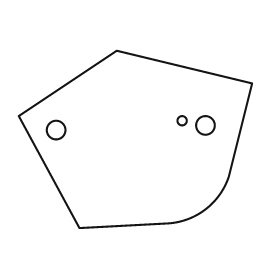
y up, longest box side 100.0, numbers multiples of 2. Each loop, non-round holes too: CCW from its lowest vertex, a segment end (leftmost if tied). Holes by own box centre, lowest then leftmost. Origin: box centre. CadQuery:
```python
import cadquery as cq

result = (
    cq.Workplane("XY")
    .moveTo(-24.0, -38.0)
    .lineTo(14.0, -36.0)
    .threePointArc((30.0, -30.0), (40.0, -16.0))
    .lineTo(50.0, 24.0)
    .lineTo(-8.0, 38.0)
    .lineTo(-50.0, 10.0)
    .close()
    .moveTo(-34.0, 4.0)
    .circle(4.0)
    .moveTo(30.0, 6.0)
    .circle(4.0)
    .moveTo(20.0, 8.0)
    .circle(2.0)
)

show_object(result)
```